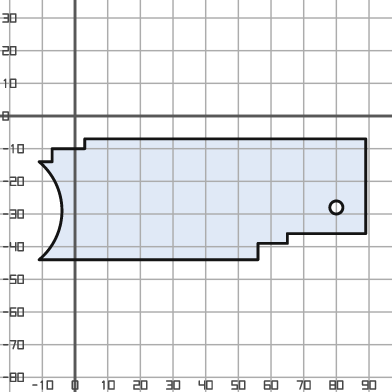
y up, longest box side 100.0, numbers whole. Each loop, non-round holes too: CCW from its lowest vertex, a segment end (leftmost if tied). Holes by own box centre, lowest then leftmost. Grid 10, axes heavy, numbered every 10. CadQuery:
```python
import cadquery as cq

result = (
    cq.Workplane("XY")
    .moveTo(-11.0, -44.0)
    .lineTo(56.0, -44.0)
    .lineTo(56.0, -39.0)
    .lineTo(65.0, -39.0)
    .lineTo(65.0, -36.0)
    .lineTo(89.0, -36.0)
    .lineTo(89.0, -7.0)
    .lineTo(3.0, -7.0)
    .lineTo(3.0, -10.0)
    .lineTo(-7.0, -10.0)
    .lineTo(-7.0, -14.0)
    .lineTo(-11.0, -14.0)
    .threePointArc((-4.0, -29.0), (-11.0, -44.0))
    .close()
    .moveTo(80.0, -28.0)
    .circle(2.0)
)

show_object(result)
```